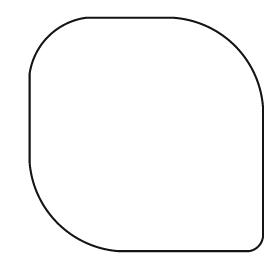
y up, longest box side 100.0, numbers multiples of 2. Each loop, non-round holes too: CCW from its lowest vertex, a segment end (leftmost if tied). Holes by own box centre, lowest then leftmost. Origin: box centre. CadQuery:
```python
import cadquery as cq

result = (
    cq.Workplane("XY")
    .moveTo(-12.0, -50.0)
    .lineTo(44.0, -50.0)
    .threePointArc((48.0, -48.0), (50.0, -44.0))
    .lineTo(50.0, 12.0)
    .threePointArc((38.0, 38.0), (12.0, 50.0))
    .lineTo(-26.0, 50.0)
    .threePointArc((-42.0, 42.0), (-50.0, 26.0))
    .lineTo(-50.0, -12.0)
    .threePointArc((-38.0, -38.0), (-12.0, -50.0))
    .close()
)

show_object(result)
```